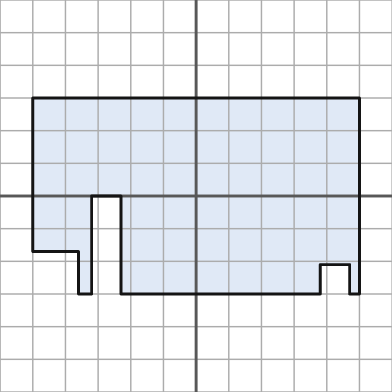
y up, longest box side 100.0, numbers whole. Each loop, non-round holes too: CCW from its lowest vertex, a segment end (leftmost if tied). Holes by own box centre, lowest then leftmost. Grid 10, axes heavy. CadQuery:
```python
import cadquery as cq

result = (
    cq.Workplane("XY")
    .moveTo(-36.0, -30.0)
    .lineTo(-32.0, -30.0)
    .lineTo(-32.0, 0.0)
    .lineTo(-23.0, 0.0)
    .lineTo(-23.0, -30.0)
    .lineTo(38.0, -30.0)
    .lineTo(38.0, -21.0)
    .lineTo(47.0, -21.0)
    .lineTo(47.0, -30.0)
    .lineTo(50.0, -30.0)
    .lineTo(50.0, 30.0)
    .lineTo(-50.0, 30.0)
    .lineTo(-50.0, -17.0)
    .lineTo(-36.0, -17.0)
    .close()
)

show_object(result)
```